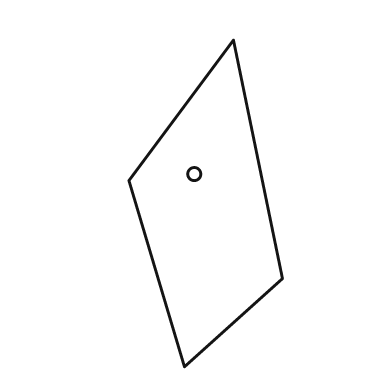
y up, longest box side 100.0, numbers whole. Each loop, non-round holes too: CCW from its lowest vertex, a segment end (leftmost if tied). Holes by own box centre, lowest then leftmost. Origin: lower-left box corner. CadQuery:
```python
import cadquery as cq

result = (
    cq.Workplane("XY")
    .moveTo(17.0, 0.0)
    .lineTo(47.0, 27.0)
    .lineTo(32.0, 100.0)
    .lineTo(0.0, 57.0)
    .close()
    .moveTo(20.0, 59.0)
    .circle(2.0)
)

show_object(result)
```